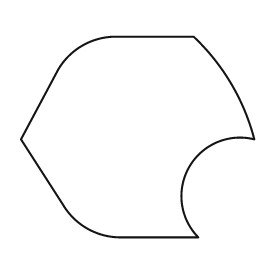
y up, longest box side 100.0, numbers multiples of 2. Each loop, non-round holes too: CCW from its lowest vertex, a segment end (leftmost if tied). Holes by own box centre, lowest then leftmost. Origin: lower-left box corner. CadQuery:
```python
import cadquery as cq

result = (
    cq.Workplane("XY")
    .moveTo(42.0, 0.0)
    .lineTo(76.0, 0.0)
    .threePointArc((72.0, 30.0), (100.0, 42.0))
    .threePointArc((90.0, 66.0), (74.0, 86.0))
    .lineTo(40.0, 86.0)
    .threePointArc((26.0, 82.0), (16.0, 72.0))
    .lineTo(0.0, 42.0)
    .lineTo(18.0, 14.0)
    .threePointArc((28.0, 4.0), (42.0, 0.0))
    .close()
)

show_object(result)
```